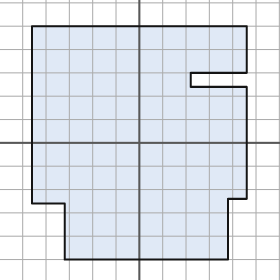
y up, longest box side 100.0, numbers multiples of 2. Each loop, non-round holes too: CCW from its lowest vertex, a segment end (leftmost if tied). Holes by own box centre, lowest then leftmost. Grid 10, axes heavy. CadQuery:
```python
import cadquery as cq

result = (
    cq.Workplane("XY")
    .moveTo(-32.0, -50.0)
    .lineTo(38.0, -50.0)
    .lineTo(38.0, -24.0)
    .lineTo(46.0, -24.0)
    .lineTo(46.0, 24.0)
    .lineTo(22.0, 24.0)
    .lineTo(22.0, 30.0)
    .lineTo(46.0, 30.0)
    .lineTo(46.0, 50.0)
    .lineTo(-46.0, 50.0)
    .lineTo(-46.0, -26.0)
    .lineTo(-32.0, -26.0)
    .close()
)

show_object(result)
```